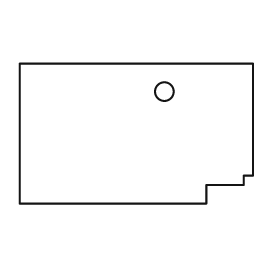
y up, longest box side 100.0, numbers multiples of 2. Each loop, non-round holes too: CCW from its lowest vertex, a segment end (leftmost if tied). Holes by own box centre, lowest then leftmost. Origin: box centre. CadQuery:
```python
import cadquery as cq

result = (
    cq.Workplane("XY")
    .moveTo(-50.0, -30.0)
    .lineTo(30.0, -30.0)
    .lineTo(30.0, -22.0)
    .lineTo(46.0, -22.0)
    .lineTo(46.0, -18.0)
    .lineTo(50.0, -18.0)
    .lineTo(50.0, 30.0)
    .lineTo(-50.0, 30.0)
    .close()
    .moveTo(12.0, 18.0)
    .circle(4.0)
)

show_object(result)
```